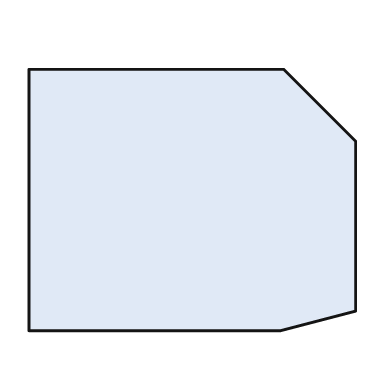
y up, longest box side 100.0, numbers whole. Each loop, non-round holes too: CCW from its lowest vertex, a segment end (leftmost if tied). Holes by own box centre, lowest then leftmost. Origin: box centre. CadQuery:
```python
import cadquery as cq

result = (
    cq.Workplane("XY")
    .moveTo(-50.0, -40.0)
    .lineTo(27.0, -40.0)
    .lineTo(50.0, -34.0)
    .lineTo(50.0, 18.0)
    .lineTo(28.0, 40.0)
    .lineTo(-50.0, 40.0)
    .close()
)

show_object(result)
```